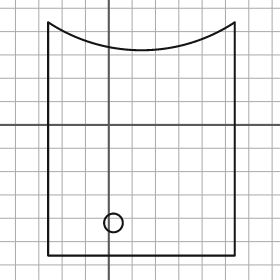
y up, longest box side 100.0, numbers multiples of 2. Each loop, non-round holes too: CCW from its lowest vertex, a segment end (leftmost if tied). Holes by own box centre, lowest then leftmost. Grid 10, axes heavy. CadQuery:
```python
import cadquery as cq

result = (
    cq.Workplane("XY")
    .moveTo(-26.0, -56.0)
    .lineTo(54.0, -56.0)
    .lineTo(54.0, 44.0)
    .threePointArc((14.0, 32.0), (-26.0, 44.0))
    .close()
    .moveTo(2.0, -42.0)
    .circle(4.0)
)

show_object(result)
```